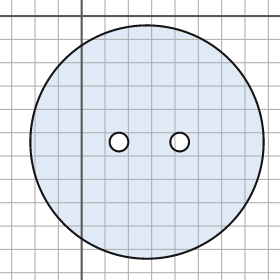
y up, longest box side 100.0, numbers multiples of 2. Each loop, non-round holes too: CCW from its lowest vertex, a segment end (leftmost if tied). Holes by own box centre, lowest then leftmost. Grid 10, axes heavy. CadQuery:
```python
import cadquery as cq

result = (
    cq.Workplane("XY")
    .moveTo(28.0, -54.0)
    .circle(50.0)
    .moveTo(16.0, -54.0)
    .circle(4.0)
    .moveTo(42.0, -54.0)
    .circle(4.0)
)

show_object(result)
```